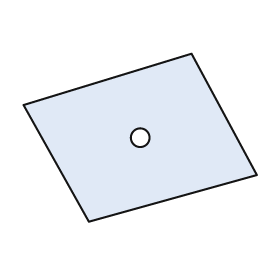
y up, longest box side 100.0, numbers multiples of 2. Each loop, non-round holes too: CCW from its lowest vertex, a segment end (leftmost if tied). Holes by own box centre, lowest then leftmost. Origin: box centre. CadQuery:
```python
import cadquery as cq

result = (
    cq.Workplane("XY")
    .moveTo(-22.0, -36.0)
    .lineTo(50.0, -16.0)
    .lineTo(22.0, 36.0)
    .lineTo(-50.0, 14.0)
    .close()
    .moveTo(0.0, 0.0)
    .circle(4.0)
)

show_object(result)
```